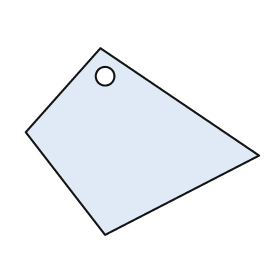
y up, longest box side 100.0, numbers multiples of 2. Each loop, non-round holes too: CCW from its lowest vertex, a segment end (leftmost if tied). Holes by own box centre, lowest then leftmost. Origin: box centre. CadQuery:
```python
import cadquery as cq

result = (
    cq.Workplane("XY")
    .moveTo(-16.0, -40.0)
    .lineTo(50.0, -6.0)
    .lineTo(-18.0, 40.0)
    .lineTo(-50.0, 4.0)
    .close()
    .moveTo(-16.0, 28.0)
    .circle(4.0)
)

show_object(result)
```